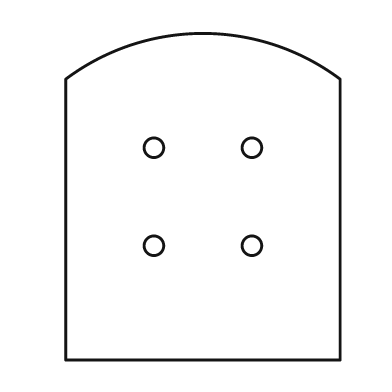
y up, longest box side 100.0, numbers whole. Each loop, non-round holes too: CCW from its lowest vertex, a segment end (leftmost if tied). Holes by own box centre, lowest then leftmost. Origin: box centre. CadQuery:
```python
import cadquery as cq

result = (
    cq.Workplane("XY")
    .moveTo(-42.0, -50.0)
    .lineTo(42.0, -50.0)
    .lineTo(42.0, 36.0)
    .threePointArc((0.0, 50.0), (-42.0, 36.0))
    .close()
    .moveTo(-15.0, -15.0)
    .circle(3.0)
    .moveTo(15.0, -15.0)
    .circle(3.0)
    .moveTo(-15.0, 15.0)
    .circle(3.0)
    .moveTo(15.0, 15.0)
    .circle(3.0)
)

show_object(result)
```